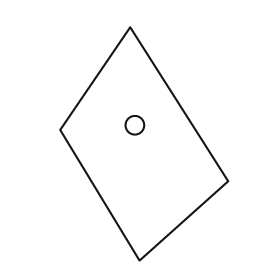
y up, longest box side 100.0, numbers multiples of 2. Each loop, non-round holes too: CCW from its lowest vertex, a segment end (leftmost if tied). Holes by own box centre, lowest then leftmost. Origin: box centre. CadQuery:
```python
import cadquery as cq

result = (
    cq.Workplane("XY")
    .moveTo(-2.0, -50.0)
    .lineTo(36.0, -16.0)
    .lineTo(-6.0, 50.0)
    .lineTo(-36.0, 6.0)
    .close()
    .moveTo(-4.0, 8.0)
    .circle(4.0)
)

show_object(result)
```